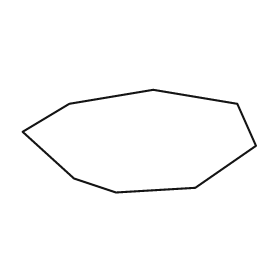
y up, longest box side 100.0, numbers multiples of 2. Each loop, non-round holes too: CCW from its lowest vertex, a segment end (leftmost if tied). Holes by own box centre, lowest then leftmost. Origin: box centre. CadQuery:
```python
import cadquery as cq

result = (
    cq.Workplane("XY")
    .moveTo(-10.0, -22.0)
    .lineTo(24.0, -20.0)
    .lineTo(50.0, -2.0)
    .lineTo(42.0, 16.0)
    .lineTo(6.0, 22.0)
    .lineTo(-30.0, 16.0)
    .lineTo(-50.0, 4.0)
    .lineTo(-28.0, -16.0)
    .close()
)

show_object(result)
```